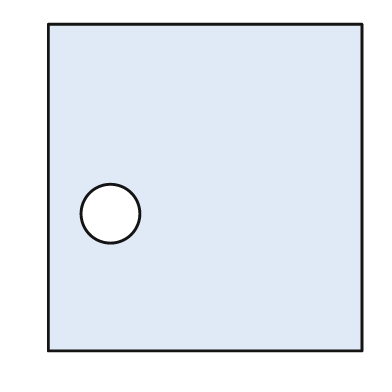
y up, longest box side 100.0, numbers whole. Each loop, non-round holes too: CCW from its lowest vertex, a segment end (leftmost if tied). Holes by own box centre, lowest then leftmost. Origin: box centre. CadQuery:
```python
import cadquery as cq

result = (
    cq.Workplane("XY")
    .moveTo(-48.0, -50.0)
    .lineTo(48.0, -50.0)
    .lineTo(48.0, 50.0)
    .lineTo(-48.0, 50.0)
    .close()
    .moveTo(-29.0, -8.0)
    .circle(9.0)
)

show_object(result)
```